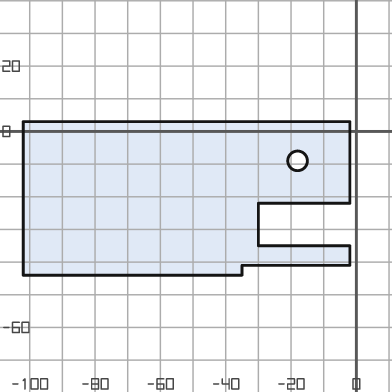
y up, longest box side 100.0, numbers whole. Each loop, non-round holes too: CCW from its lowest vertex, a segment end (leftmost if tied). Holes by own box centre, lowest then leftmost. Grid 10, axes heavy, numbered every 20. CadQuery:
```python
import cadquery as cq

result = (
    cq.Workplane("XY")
    .moveTo(-102.0, -44.0)
    .lineTo(-35.0, -44.0)
    .lineTo(-35.0, -41.0)
    .lineTo(-2.0, -41.0)
    .lineTo(-2.0, -35.0)
    .lineTo(-30.0, -35.0)
    .lineTo(-30.0, -22.0)
    .lineTo(-2.0, -22.0)
    .lineTo(-2.0, 3.0)
    .lineTo(-102.0, 3.0)
    .close()
    .moveTo(-18.0, -9.0)
    .circle(3.0)
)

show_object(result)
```